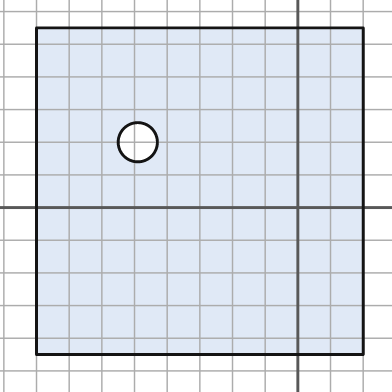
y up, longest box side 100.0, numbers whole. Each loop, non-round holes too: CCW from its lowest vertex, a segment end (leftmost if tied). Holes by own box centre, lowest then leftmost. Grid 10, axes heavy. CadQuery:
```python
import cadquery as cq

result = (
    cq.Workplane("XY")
    .moveTo(-80.0, -45.0)
    .lineTo(20.0, -45.0)
    .lineTo(20.0, 55.0)
    .lineTo(-80.0, 55.0)
    .close()
    .moveTo(-49.0, 20.0)
    .circle(6.0)
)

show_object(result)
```